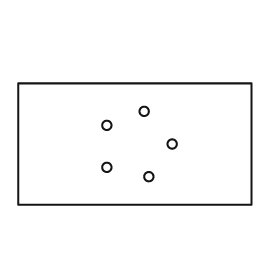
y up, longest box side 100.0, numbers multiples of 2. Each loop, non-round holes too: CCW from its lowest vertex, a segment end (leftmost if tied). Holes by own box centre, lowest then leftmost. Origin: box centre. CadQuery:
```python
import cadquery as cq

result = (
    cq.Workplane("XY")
    .moveTo(-50.0, -26.0)
    .lineTo(50.0, -26.0)
    .lineTo(50.0, 26.0)
    .lineTo(-50.0, 26.0)
    .close()
    .moveTo(6.0, -14.0)
    .circle(2.0)
    .moveTo(-12.0, -10.0)
    .circle(2.0)
    .moveTo(16.0, 0.0)
    .circle(2.0)
    .moveTo(-12.0, 8.0)
    .circle(2.0)
    .moveTo(4.0, 14.0)
    .circle(2.0)
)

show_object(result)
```